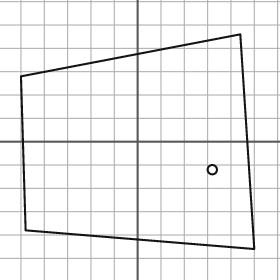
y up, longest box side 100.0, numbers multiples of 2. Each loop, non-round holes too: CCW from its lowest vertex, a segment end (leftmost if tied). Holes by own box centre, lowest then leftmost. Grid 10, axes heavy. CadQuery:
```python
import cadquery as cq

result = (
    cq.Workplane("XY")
    .moveTo(50.0, -46.0)
    .lineTo(44.0, 46.0)
    .lineTo(-50.0, 28.0)
    .lineTo(-48.0, -38.0)
    .close()
    .moveTo(32.0, -12.0)
    .circle(2.0)
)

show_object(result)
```